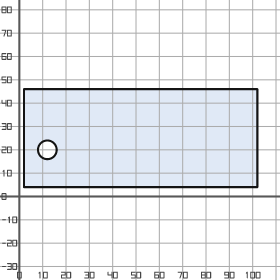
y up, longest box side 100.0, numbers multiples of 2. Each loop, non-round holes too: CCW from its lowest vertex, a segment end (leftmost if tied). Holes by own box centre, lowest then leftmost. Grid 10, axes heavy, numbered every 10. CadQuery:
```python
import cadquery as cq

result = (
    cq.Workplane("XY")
    .moveTo(2.0, 4.0)
    .lineTo(102.0, 4.0)
    .lineTo(102.0, 46.0)
    .lineTo(2.0, 46.0)
    .close()
    .moveTo(12.0, 20.0)
    .circle(4.0)
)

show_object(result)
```